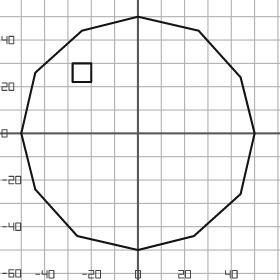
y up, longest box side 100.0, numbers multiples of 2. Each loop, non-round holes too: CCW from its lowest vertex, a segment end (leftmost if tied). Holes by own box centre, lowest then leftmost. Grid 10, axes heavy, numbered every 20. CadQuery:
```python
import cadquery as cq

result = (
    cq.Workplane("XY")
    .moveTo(0.0, -50.0)
    .lineTo(24.0, -44.0)
    .lineTo(44.0, -26.0)
    .lineTo(50.0, 0.0)
    .lineTo(44.0, 24.0)
    .lineTo(26.0, 44.0)
    .lineTo(0.0, 50.0)
    .lineTo(-24.0, 44.0)
    .lineTo(-44.0, 26.0)
    .lineTo(-50.0, 0.0)
    .lineTo(-44.0, -24.0)
    .lineTo(-26.0, -44.0)
    .close()
    .moveTo(-28.0, 22.0)
    .lineTo(-20.0, 22.0)
    .lineTo(-20.0, 30.0)
    .lineTo(-28.0, 30.0)
    .close()
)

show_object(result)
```